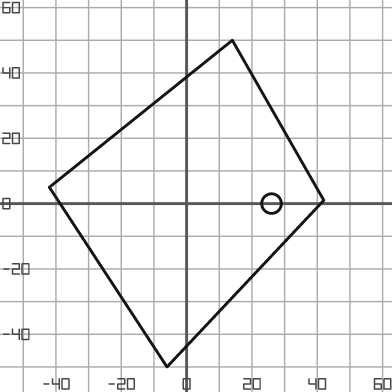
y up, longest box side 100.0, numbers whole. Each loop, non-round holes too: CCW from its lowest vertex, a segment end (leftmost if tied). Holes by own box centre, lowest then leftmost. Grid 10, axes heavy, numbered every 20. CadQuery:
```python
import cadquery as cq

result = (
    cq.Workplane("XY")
    .moveTo(-6.0, -50.0)
    .lineTo(42.0, 1.0)
    .lineTo(14.0, 50.0)
    .lineTo(-42.0, 5.0)
    .close()
    .moveTo(26.0, 0.0)
    .circle(3.0)
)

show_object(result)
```